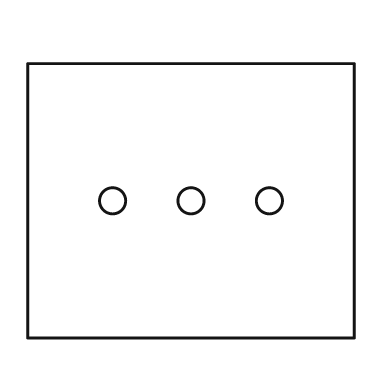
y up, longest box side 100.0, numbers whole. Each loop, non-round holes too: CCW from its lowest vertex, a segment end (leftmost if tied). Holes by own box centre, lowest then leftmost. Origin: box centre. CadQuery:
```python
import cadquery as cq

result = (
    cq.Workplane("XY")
    .moveTo(-50.0, -42.0)
    .lineTo(50.0, -42.0)
    .lineTo(50.0, 42.0)
    .lineTo(-50.0, 42.0)
    .close()
    .moveTo(-24.0, 0.0)
    .circle(4.0)
    .moveTo(0.0, 0.0)
    .circle(4.0)
    .moveTo(24.0, 0.0)
    .circle(4.0)
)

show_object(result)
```